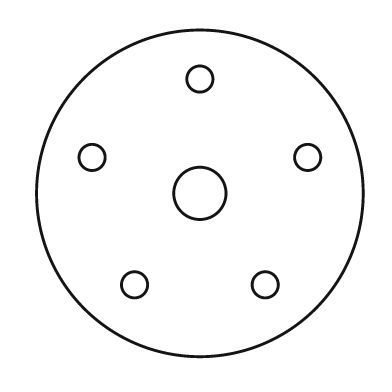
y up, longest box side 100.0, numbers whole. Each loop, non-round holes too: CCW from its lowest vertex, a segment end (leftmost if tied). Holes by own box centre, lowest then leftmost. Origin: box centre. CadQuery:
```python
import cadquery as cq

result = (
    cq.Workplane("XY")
    .moveTo(0.0, 0.0)
    .circle(50.0)
    .moveTo(-20.0, -28.0)
    .circle(4.0)
    .moveTo(20.0, -28.0)
    .circle(4.0)
    .moveTo(0.0, 0.0)
    .circle(8.0)
    .moveTo(-33.0, 11.0)
    .circle(4.0)
    .moveTo(33.0, 11.0)
    .circle(4.0)
    .moveTo(0.0, 35.0)
    .circle(4.0)
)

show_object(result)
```